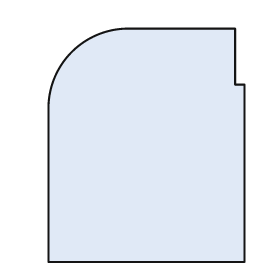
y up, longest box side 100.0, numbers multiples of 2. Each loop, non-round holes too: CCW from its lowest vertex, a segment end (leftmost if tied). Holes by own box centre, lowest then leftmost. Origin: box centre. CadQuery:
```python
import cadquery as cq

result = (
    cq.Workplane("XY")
    .moveTo(-42.0, -50.0)
    .lineTo(42.0, -50.0)
    .lineTo(42.0, 26.0)
    .lineTo(38.0, 26.0)
    .lineTo(38.0, 50.0)
    .lineTo(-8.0, 50.0)
    .threePointArc((-32.0, 40.0), (-42.0, 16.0))
    .close()
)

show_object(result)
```